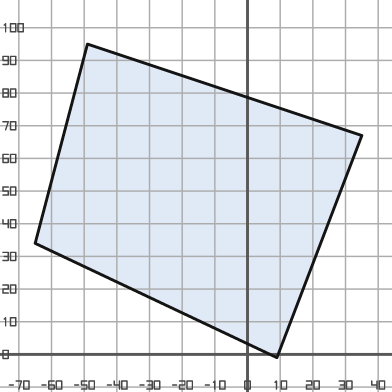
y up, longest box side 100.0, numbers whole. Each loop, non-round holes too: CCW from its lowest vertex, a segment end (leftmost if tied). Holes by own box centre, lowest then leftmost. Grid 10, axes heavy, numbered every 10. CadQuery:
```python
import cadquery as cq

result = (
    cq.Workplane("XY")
    .moveTo(9.0, -1.0)
    .lineTo(35.0, 67.0)
    .lineTo(-49.0, 95.0)
    .lineTo(-65.0, 34.0)
    .close()
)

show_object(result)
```